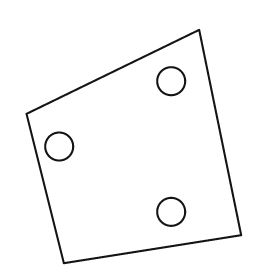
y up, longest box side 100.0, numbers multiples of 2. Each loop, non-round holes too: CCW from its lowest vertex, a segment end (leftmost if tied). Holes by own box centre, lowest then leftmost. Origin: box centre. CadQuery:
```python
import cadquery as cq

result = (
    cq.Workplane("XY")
    .moveTo(-30.0, -50.0)
    .lineTo(46.0, -38.0)
    .lineTo(28.0, 50.0)
    .lineTo(-46.0, 14.0)
    .close()
    .moveTo(16.0, -28.0)
    .circle(6.0)
    .moveTo(-32.0, 0.0)
    .circle(6.0)
    .moveTo(16.0, 28.0)
    .circle(6.0)
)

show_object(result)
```